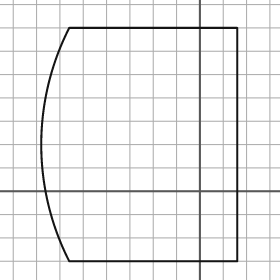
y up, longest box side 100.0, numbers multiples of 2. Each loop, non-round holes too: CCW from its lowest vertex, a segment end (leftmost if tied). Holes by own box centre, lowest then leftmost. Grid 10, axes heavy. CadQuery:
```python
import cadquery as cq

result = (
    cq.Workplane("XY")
    .moveTo(-56.0, -30.0)
    .lineTo(16.0, -30.0)
    .lineTo(16.0, 70.0)
    .lineTo(-56.0, 70.0)
    .threePointArc((-68.0, 20.0), (-56.0, -30.0))
    .close()
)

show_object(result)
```